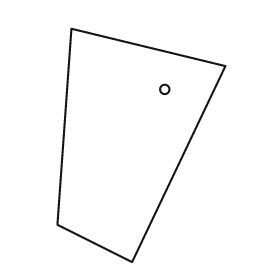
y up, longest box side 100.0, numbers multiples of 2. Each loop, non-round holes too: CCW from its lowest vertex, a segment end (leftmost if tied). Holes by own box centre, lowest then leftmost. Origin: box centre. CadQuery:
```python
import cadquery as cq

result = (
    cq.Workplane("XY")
    .moveTo(-4.0, -50.0)
    .lineTo(36.0, 34.0)
    .lineTo(-30.0, 50.0)
    .lineTo(-36.0, -34.0)
    .close()
    .moveTo(10.0, 24.0)
    .circle(2.0)
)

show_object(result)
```